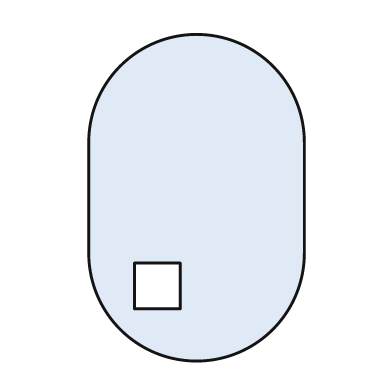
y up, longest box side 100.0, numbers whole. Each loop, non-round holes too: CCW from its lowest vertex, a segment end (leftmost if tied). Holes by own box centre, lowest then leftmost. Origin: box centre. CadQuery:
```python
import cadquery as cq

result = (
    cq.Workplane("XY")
    .moveTo(-33.0, -17.0)
    .threePointArc((0.0, -50.0), (33.0, -17.0))
    .lineTo(33.0, 17.0)
    .threePointArc((0.0, 50.0), (-33.0, 17.0))
    .close()
    .moveTo(-19.0, -34.0)
    .lineTo(-5.0, -34.0)
    .lineTo(-5.0, -20.0)
    .lineTo(-19.0, -20.0)
    .close()
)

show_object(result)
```